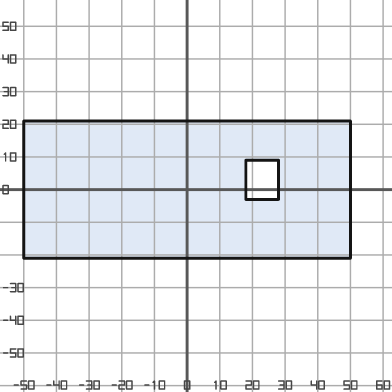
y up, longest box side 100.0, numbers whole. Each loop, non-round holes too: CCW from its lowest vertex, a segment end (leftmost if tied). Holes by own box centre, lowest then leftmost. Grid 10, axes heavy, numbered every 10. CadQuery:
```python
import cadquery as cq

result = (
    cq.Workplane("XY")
    .moveTo(-50.0, -21.0)
    .lineTo(50.0, -21.0)
    .lineTo(50.0, 21.0)
    .lineTo(-50.0, 21.0)
    .close()
    .moveTo(18.0, -3.0)
    .lineTo(28.0, -3.0)
    .lineTo(28.0, 9.0)
    .lineTo(18.0, 9.0)
    .close()
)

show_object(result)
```